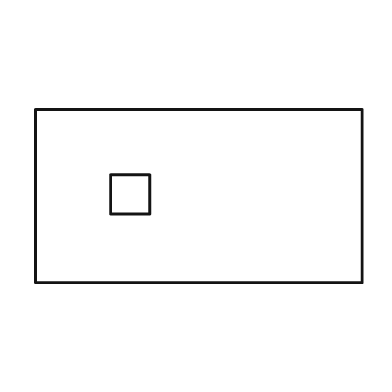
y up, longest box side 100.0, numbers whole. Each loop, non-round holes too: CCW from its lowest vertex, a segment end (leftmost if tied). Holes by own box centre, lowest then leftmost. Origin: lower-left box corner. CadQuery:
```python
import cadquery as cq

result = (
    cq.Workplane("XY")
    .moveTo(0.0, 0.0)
    .lineTo(100.0, 0.0)
    .lineTo(100.0, 53.0)
    .lineTo(0.0, 53.0)
    .close()
    .moveTo(23.0, 21.0)
    .lineTo(35.0, 21.0)
    .lineTo(35.0, 33.0)
    .lineTo(23.0, 33.0)
    .close()
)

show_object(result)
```